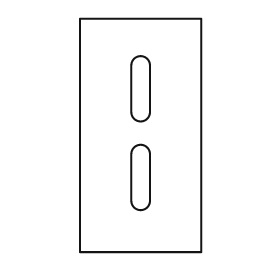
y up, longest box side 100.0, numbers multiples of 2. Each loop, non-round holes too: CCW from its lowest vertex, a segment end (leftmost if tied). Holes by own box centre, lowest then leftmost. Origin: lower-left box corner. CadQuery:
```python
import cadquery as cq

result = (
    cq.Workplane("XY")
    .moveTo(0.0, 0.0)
    .lineTo(52.0, 0.0)
    .lineTo(52.0, 100.0)
    .lineTo(0.0, 100.0)
    .close()
    .moveTo(22.0, 22.0)
    .threePointArc((26.0, 18.0), (30.0, 22.0))
    .lineTo(30.0, 42.0)
    .threePointArc((26.0, 46.0), (22.0, 42.0))
    .close()
    .moveTo(22.0, 60.0)
    .threePointArc((26.0, 56.0), (30.0, 60.0))
    .lineTo(30.0, 80.0)
    .threePointArc((26.0, 84.0), (22.0, 80.0))
    .close()
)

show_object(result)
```